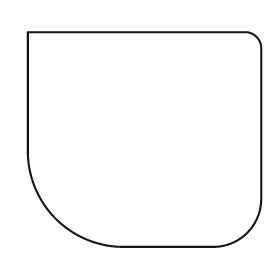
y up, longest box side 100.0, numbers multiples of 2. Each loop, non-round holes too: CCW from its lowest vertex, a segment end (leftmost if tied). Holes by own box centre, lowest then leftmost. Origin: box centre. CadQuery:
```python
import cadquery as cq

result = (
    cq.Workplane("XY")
    .moveTo(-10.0, -46.0)
    .lineTo(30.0, -46.0)
    .threePointArc((44.0, -40.0), (50.0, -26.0))
    .lineTo(50.0, 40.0)
    .threePointArc((48.0, 44.0), (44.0, 46.0))
    .lineTo(-50.0, 46.0)
    .lineTo(-50.0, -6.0)
    .threePointArc((-38.0, -34.0), (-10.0, -46.0))
    .close()
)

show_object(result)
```